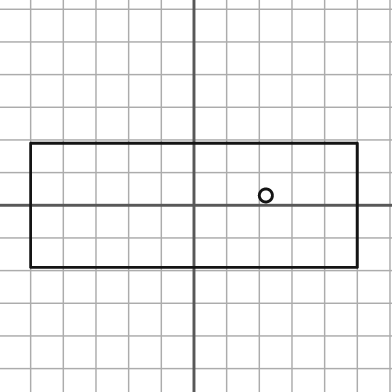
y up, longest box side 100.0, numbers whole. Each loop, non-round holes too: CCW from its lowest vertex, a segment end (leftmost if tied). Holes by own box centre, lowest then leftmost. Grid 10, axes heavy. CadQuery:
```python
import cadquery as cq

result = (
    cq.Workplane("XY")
    .moveTo(-50.0, -19.0)
    .lineTo(50.0, -19.0)
    .lineTo(50.0, 19.0)
    .lineTo(-50.0, 19.0)
    .close()
    .moveTo(22.0, 3.0)
    .circle(2.0)
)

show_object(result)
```